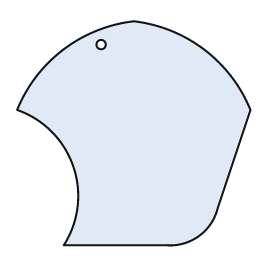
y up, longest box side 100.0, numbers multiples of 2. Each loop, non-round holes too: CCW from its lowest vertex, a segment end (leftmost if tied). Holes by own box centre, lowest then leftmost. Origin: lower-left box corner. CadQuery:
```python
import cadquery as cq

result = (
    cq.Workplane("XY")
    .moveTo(20.0, 0.0)
    .lineTo(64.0, 0.0)
    .threePointArc((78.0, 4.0), (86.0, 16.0))
    .lineTo(100.0, 58.0)
    .threePointArc((80.0, 84.0), (50.0, 96.0))
    .threePointArc((20.0, 84.0), (0.0, 58.0))
    .threePointArc((24.0, 34.0), (20.0, 0.0))
    .close()
    .moveTo(36.0, 86.0)
    .circle(2.0)
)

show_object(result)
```